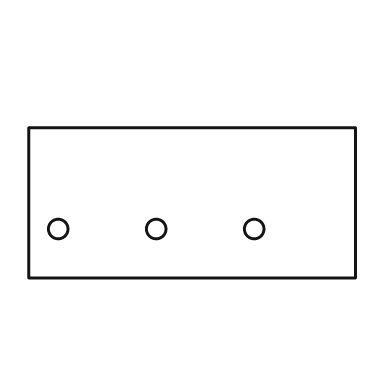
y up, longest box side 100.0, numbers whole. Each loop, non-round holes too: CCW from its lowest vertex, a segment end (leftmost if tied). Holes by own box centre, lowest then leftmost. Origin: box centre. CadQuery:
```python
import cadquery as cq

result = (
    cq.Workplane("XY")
    .moveTo(-50.0, -23.0)
    .lineTo(50.0, -23.0)
    .lineTo(50.0, 23.0)
    .lineTo(-50.0, 23.0)
    .close()
    .moveTo(-41.0, -8.0)
    .circle(3.0)
    .moveTo(-11.0, -8.0)
    .circle(3.0)
    .moveTo(19.0, -8.0)
    .circle(3.0)
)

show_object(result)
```